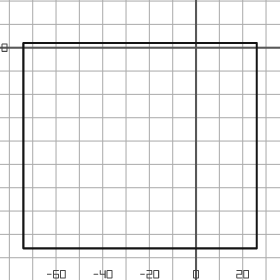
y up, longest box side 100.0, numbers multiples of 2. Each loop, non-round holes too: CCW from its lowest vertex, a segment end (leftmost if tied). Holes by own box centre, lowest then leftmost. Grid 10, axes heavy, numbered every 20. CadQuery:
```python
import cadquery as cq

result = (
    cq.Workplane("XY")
    .moveTo(-74.0, -86.0)
    .lineTo(26.0, -86.0)
    .lineTo(26.0, 2.0)
    .lineTo(-74.0, 2.0)
    .close()
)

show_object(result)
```